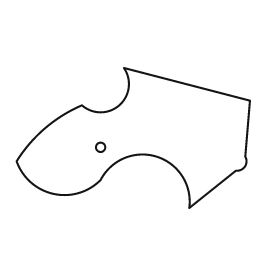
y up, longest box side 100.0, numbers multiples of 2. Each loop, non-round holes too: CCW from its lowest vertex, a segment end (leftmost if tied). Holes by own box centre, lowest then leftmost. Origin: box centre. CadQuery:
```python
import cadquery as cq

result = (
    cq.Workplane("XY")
    .moveTo(24.0, -30.0)
    .lineTo(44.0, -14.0)
    .threePointArc((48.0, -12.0), (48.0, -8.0))
    .lineTo(50.0, 16.0)
    .lineTo(-4.0, 30.0)
    .threePointArc((-6.0, 14.0), (-22.0, 14.0))
    .threePointArc((-38.0, 4.0), (-50.0, -10.0))
    .threePointArc((-34.0, -24.0), (-14.0, -18.0))
    .threePointArc((10.0, -8.0), (24.0, -30.0))
    .close()
    .moveTo(-14.0, -4.0)
    .circle(2.0)
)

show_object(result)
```